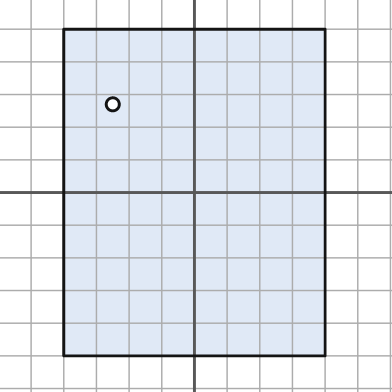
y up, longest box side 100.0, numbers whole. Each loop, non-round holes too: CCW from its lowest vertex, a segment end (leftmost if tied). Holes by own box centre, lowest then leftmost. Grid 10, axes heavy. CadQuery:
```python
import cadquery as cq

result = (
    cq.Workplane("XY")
    .moveTo(-40.0, -50.0)
    .lineTo(40.0, -50.0)
    .lineTo(40.0, 50.0)
    .lineTo(-40.0, 50.0)
    .close()
    .moveTo(-25.0, 27.0)
    .circle(2.0)
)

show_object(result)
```